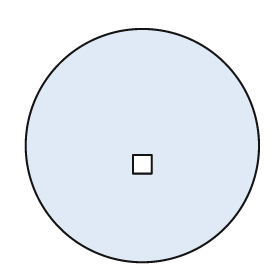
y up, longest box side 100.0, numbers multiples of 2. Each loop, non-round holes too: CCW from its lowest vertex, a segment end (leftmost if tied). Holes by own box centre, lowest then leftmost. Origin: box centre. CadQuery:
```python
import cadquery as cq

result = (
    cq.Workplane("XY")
    .moveTo(0.0, 0.0)
    .circle(50.0)
    .moveTo(-4.0, -12.0)
    .lineTo(4.0, -12.0)
    .lineTo(4.0, -4.0)
    .lineTo(-4.0, -4.0)
    .close()
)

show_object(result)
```